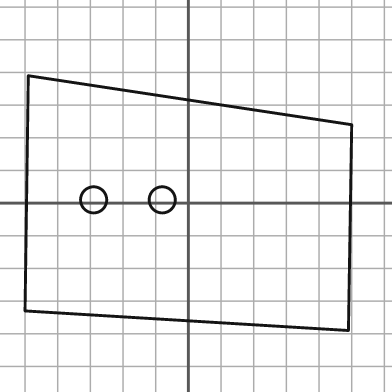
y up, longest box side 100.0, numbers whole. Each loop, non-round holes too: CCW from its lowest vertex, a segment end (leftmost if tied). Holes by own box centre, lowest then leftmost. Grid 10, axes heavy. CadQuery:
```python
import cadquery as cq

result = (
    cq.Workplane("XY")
    .moveTo(49.0, -39.0)
    .lineTo(50.0, 24.0)
    .lineTo(-49.0, 39.0)
    .lineTo(-50.0, -33.0)
    .close()
    .moveTo(-29.0, 1.0)
    .circle(4.0)
    .moveTo(-8.0, 1.0)
    .circle(4.0)
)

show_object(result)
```